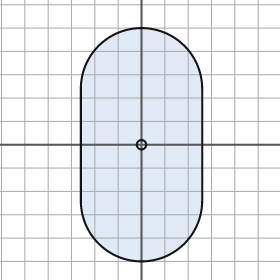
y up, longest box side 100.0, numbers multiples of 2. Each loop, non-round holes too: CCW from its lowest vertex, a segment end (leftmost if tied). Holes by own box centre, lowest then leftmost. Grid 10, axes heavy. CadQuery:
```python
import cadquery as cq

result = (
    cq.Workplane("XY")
    .moveTo(-26.0, -24.0)
    .threePointArc((0.0, -50.0), (26.0, -24.0))
    .lineTo(26.0, 24.0)
    .threePointArc((0.0, 50.0), (-26.0, 24.0))
    .close()
    .moveTo(0.0, 0.0)
    .circle(2.0)
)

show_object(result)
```